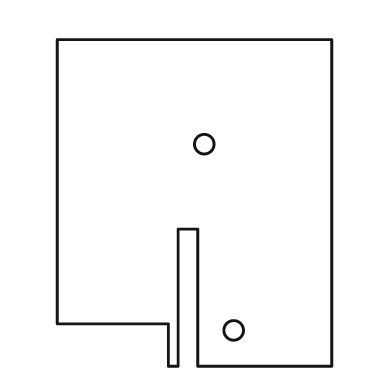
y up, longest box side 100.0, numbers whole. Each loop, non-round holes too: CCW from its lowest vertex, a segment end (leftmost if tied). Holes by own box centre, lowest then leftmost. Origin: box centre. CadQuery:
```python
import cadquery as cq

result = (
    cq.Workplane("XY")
    .moveTo(-8.0, -50.0)
    .lineTo(-5.0, -50.0)
    .lineTo(-5.0, -8.0)
    .lineTo(1.0, -8.0)
    .lineTo(1.0, -50.0)
    .lineTo(42.0, -50.0)
    .lineTo(42.0, 50.0)
    .lineTo(-42.0, 50.0)
    .lineTo(-42.0, -37.0)
    .lineTo(-8.0, -37.0)
    .close()
    .moveTo(12.0, -39.0)
    .circle(3.0)
    .moveTo(3.0, 18.0)
    .circle(3.0)
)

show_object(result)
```